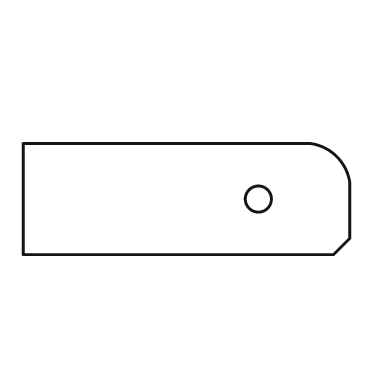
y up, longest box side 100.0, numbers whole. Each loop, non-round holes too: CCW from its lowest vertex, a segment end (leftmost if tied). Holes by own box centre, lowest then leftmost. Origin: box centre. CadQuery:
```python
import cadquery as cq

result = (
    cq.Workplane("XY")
    .moveTo(-50.0, -17.0)
    .lineTo(45.0, -17.0)
    .lineTo(50.0, -12.0)
    .lineTo(50.0, 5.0)
    .threePointArc((46.0, 13.0), (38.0, 17.0))
    .lineTo(-50.0, 17.0)
    .close()
    .moveTo(22.0, 0.0)
    .circle(4.0)
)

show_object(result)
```